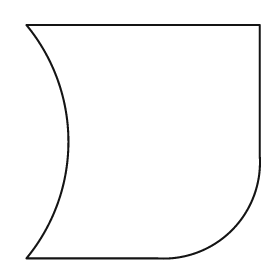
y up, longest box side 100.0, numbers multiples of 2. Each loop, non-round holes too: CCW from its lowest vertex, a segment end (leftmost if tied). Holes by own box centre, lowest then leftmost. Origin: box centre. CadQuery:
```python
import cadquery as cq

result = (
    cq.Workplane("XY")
    .moveTo(-50.0, -50.0)
    .lineTo(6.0, -50.0)
    .threePointArc((38.0, -38.0), (50.0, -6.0))
    .lineTo(50.0, 50.0)
    .lineTo(-50.0, 50.0)
    .threePointArc((-32.0, 0.0), (-50.0, -50.0))
    .close()
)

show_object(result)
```